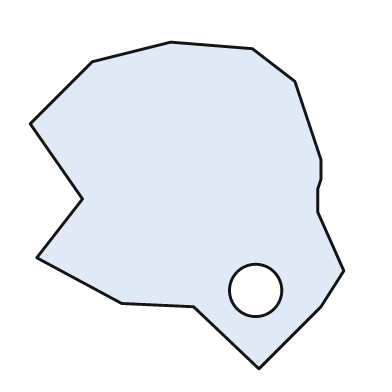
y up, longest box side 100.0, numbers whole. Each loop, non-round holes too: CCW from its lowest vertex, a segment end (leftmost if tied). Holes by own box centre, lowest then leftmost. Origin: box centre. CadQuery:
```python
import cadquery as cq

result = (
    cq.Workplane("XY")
    .moveTo(22.0, -50.0)
    .lineTo(41.0, -31.0)
    .lineTo(48.0, -20.0)
    .lineTo(40.0, -2.0)
    .lineTo(40.0, 5.0)
    .lineTo(41.0, 8.0)
    .lineTo(41.0, 14.0)
    .lineTo(33.0, 38.0)
    .lineTo(20.0, 48.0)
    .lineTo(-5.0, 50.0)
    .lineTo(-29.0, 44.0)
    .lineTo(-48.0, 25.0)
    .lineTo(-32.0, 2.0)
    .lineTo(-46.0, -16.0)
    .lineTo(-20.0, -30.0)
    .lineTo(2.0, -31.0)
    .close()
    .moveTo(21.0, -26.0)
    .circle(8.0)
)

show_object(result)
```